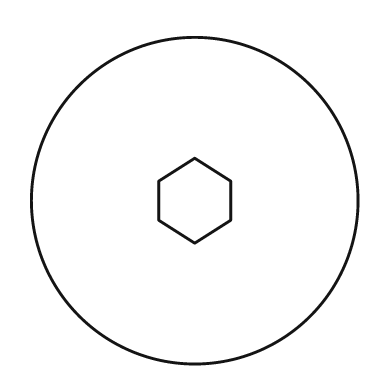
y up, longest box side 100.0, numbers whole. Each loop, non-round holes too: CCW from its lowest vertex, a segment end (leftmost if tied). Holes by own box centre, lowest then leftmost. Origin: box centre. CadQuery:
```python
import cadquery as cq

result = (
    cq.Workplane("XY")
    .moveTo(0.0, 0.0)
    .circle(50.0)
    .moveTo(0.0, -13.0)
    .lineTo(11.0, -6.0)
    .lineTo(11.0, 6.0)
    .lineTo(0.0, 13.0)
    .lineTo(-11.0, 6.0)
    .lineTo(-11.0, -6.0)
    .close()
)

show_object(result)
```